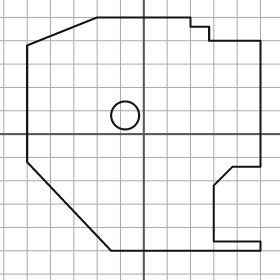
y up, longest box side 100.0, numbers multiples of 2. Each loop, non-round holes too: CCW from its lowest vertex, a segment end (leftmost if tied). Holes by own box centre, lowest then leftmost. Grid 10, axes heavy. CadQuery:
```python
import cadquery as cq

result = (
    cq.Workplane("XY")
    .moveTo(-14.0, -50.0)
    .lineTo(50.0, -50.0)
    .lineTo(50.0, -46.0)
    .lineTo(30.0, -46.0)
    .lineTo(30.0, -22.0)
    .lineTo(38.0, -14.0)
    .lineTo(50.0, -14.0)
    .lineTo(50.0, 40.0)
    .lineTo(28.0, 40.0)
    .lineTo(28.0, 46.0)
    .lineTo(20.0, 46.0)
    .lineTo(20.0, 50.0)
    .lineTo(-20.0, 50.0)
    .lineTo(-50.0, 38.0)
    .lineTo(-50.0, -12.0)
    .close()
    .moveTo(-8.0, 8.0)
    .circle(6.0)
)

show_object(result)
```